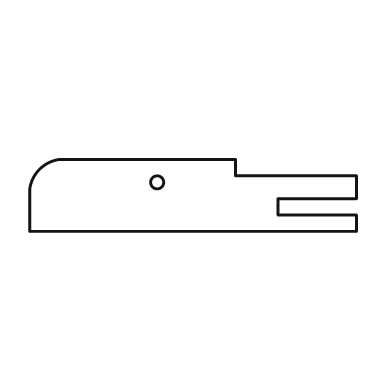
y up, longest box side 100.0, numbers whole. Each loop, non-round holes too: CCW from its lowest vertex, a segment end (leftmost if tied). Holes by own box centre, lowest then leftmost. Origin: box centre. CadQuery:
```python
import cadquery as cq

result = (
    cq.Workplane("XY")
    .moveTo(-50.0, -11.0)
    .lineTo(50.0, -11.0)
    .lineTo(50.0, -6.0)
    .lineTo(26.0, -6.0)
    .lineTo(26.0, -1.0)
    .lineTo(50.0, -1.0)
    .lineTo(50.0, 6.0)
    .lineTo(13.0, 6.0)
    .lineTo(13.0, 11.0)
    .lineTo(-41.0, 11.0)
    .threePointArc((-47.0, 8.0), (-50.0, 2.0))
    .close()
    .moveTo(-11.0, 4.0)
    .circle(2.0)
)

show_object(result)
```